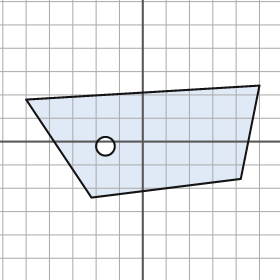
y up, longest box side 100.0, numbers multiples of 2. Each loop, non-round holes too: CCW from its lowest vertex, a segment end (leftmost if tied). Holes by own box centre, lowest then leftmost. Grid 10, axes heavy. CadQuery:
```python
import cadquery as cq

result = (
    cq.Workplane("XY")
    .moveTo(-22.0, -24.0)
    .lineTo(42.0, -16.0)
    .lineTo(50.0, 24.0)
    .lineTo(-50.0, 18.0)
    .close()
    .moveTo(-16.0, -2.0)
    .circle(4.0)
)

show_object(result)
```